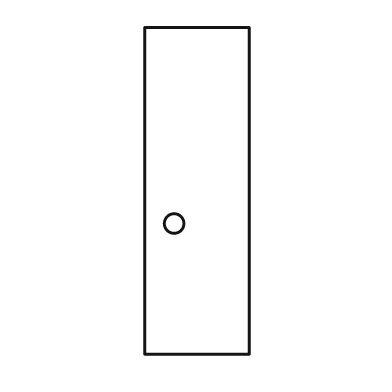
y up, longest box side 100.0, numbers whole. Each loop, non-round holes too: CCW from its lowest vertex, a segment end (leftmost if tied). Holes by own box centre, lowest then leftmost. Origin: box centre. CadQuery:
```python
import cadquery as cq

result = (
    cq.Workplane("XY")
    .moveTo(-16.0, -50.0)
    .lineTo(16.0, -50.0)
    .lineTo(16.0, 50.0)
    .lineTo(-16.0, 50.0)
    .close()
    .moveTo(-7.0, -10.0)
    .circle(3.0)
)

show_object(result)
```